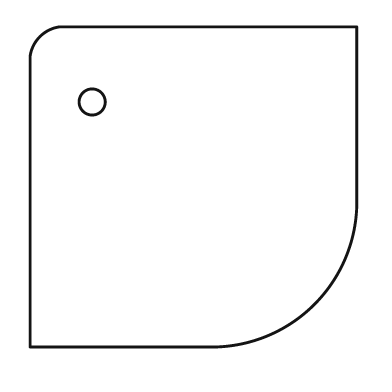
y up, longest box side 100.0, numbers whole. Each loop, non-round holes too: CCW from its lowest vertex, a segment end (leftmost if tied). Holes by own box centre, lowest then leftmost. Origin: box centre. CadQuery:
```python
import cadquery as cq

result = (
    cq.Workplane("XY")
    .moveTo(-50.0, -49.0)
    .lineTo(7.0, -49.0)
    .threePointArc((37.0, -36.0), (50.0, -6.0))
    .lineTo(50.0, 49.0)
    .lineTo(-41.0, 49.0)
    .threePointArc((-47.0, 46.0), (-50.0, 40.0))
    .close()
    .moveTo(-31.0, 26.0)
    .circle(4.0)
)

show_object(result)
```